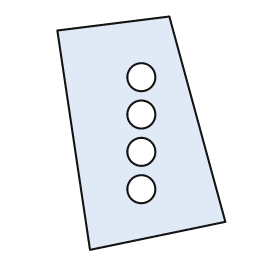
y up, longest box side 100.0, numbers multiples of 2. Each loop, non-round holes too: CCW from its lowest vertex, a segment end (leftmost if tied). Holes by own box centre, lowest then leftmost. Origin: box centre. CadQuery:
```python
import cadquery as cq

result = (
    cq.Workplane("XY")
    .moveTo(-22.0, -50.0)
    .lineTo(36.0, -38.0)
    .lineTo(12.0, 50.0)
    .lineTo(-36.0, 44.0)
    .close()
    .moveTo(0.0, -24.0)
    .circle(6.0)
    .moveTo(0.0, -8.0)
    .circle(6.0)
    .moveTo(0.0, 8.0)
    .circle(6.0)
    .moveTo(0.0, 24.0)
    .circle(6.0)
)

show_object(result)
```